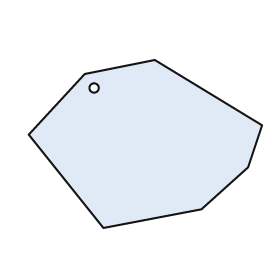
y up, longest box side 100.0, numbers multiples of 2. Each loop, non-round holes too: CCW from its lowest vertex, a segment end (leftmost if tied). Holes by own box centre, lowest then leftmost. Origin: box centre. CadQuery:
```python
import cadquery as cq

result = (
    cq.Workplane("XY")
    .moveTo(-18.0, -36.0)
    .lineTo(24.0, -28.0)
    .lineTo(44.0, -10.0)
    .lineTo(50.0, 8.0)
    .lineTo(4.0, 36.0)
    .lineTo(-26.0, 30.0)
    .lineTo(-50.0, 4.0)
    .close()
    .moveTo(-22.0, 24.0)
    .circle(2.0)
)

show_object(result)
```